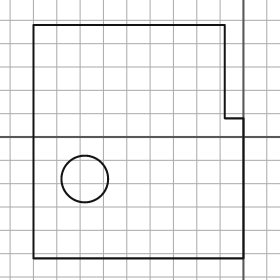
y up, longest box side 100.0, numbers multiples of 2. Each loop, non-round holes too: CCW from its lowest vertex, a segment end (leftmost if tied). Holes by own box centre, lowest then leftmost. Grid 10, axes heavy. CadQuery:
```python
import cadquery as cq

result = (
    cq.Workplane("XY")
    .moveTo(-90.0, -52.0)
    .lineTo(0.0, -52.0)
    .lineTo(0.0, 8.0)
    .lineTo(-8.0, 8.0)
    .lineTo(-8.0, 48.0)
    .lineTo(-90.0, 48.0)
    .close()
    .moveTo(-68.0, -18.0)
    .circle(10.0)
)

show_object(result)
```